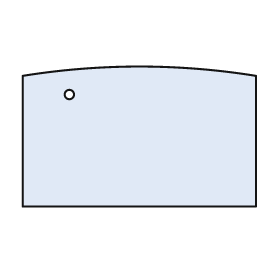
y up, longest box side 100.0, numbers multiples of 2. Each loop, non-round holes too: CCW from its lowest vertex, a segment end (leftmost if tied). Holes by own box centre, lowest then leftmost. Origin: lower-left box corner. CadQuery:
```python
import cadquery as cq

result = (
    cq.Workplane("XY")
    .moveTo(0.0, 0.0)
    .lineTo(100.0, 0.0)
    .lineTo(100.0, 56.0)
    .threePointArc((50.0, 60.0), (0.0, 56.0))
    .close()
    .moveTo(20.0, 48.0)
    .circle(2.0)
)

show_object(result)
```